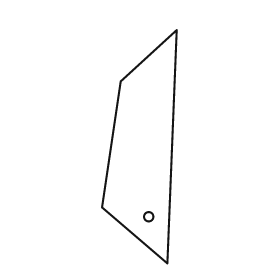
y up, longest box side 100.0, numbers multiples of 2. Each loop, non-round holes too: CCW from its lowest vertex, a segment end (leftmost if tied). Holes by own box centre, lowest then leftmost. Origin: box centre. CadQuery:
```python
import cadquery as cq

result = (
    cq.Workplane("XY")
    .moveTo(12.0, -50.0)
    .lineTo(16.0, 50.0)
    .lineTo(-8.0, 28.0)
    .lineTo(-16.0, -26.0)
    .close()
    .moveTo(4.0, -30.0)
    .circle(2.0)
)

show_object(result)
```